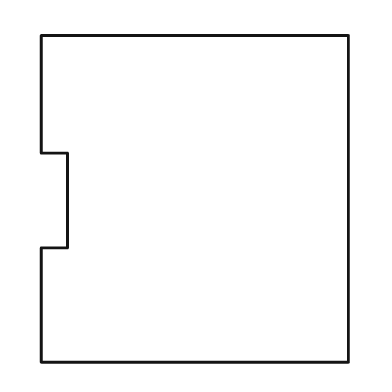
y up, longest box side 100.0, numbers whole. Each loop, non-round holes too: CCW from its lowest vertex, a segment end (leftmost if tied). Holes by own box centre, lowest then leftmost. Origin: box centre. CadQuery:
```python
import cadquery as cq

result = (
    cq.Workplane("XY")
    .moveTo(-47.0, -50.0)
    .lineTo(47.0, -50.0)
    .lineTo(47.0, 50.0)
    .lineTo(-47.0, 50.0)
    .lineTo(-47.0, 14.0)
    .lineTo(-39.0, 14.0)
    .lineTo(-39.0, -15.0)
    .lineTo(-47.0, -15.0)
    .close()
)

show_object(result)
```